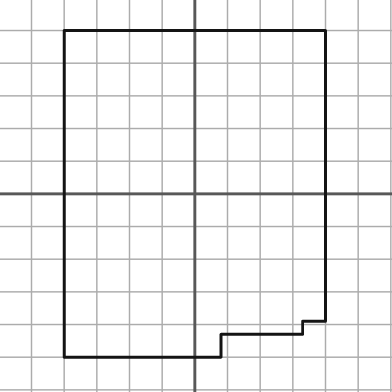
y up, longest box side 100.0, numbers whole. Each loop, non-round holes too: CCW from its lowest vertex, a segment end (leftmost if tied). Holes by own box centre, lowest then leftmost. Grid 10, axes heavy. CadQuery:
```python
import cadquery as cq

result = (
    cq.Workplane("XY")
    .moveTo(-40.0, -50.0)
    .lineTo(8.0, -50.0)
    .lineTo(8.0, -43.0)
    .lineTo(33.0, -43.0)
    .lineTo(33.0, -39.0)
    .lineTo(40.0, -39.0)
    .lineTo(40.0, 50.0)
    .lineTo(-40.0, 50.0)
    .close()
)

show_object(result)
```